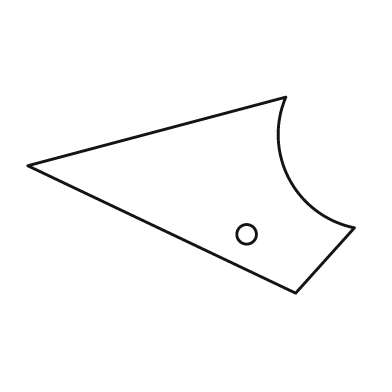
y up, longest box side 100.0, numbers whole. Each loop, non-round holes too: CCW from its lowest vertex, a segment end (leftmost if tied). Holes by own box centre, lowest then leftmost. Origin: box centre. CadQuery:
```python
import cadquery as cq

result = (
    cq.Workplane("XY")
    .moveTo(32.0, -30.0)
    .lineTo(50.0, -10.0)
    .threePointArc((30.0, 5.0), (29.0, 30.0))
    .lineTo(-50.0, 9.0)
    .close()
    .moveTo(17.0, -12.0)
    .circle(3.0)
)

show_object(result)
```